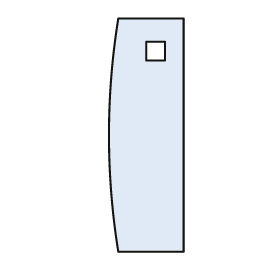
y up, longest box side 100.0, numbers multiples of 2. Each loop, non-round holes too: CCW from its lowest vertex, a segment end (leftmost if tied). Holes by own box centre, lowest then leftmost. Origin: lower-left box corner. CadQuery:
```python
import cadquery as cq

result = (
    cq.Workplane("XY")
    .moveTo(4.0, 0.0)
    .lineTo(32.0, 0.0)
    .lineTo(32.0, 100.0)
    .lineTo(4.0, 100.0)
    .threePointArc((0.0, 50.0), (4.0, 0.0))
    .close()
    .moveTo(16.0, 82.0)
    .lineTo(24.0, 82.0)
    .lineTo(24.0, 90.0)
    .lineTo(16.0, 90.0)
    .close()
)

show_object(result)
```